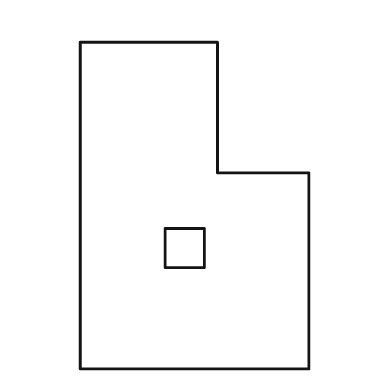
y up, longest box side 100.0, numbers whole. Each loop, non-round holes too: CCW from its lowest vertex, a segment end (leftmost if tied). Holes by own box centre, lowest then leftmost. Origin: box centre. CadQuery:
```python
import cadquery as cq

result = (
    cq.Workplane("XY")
    .moveTo(-35.0, -50.0)
    .lineTo(35.0, -50.0)
    .lineTo(35.0, 10.0)
    .lineTo(7.0, 10.0)
    .lineTo(7.0, 50.0)
    .lineTo(-35.0, 50.0)
    .close()
    .moveTo(-9.0, -19.0)
    .lineTo(3.0, -19.0)
    .lineTo(3.0, -7.0)
    .lineTo(-9.0, -7.0)
    .close()
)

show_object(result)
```